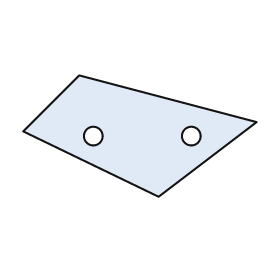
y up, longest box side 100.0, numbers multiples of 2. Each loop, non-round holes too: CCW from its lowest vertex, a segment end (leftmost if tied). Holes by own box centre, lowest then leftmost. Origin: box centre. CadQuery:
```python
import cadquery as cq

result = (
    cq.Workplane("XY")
    .moveTo(8.0, -26.0)
    .lineTo(50.0, 6.0)
    .lineTo(-26.0, 26.0)
    .lineTo(-50.0, 2.0)
    .close()
    .moveTo(-20.0, 0.0)
    .circle(4.0)
    .moveTo(22.0, 0.0)
    .circle(4.0)
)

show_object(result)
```